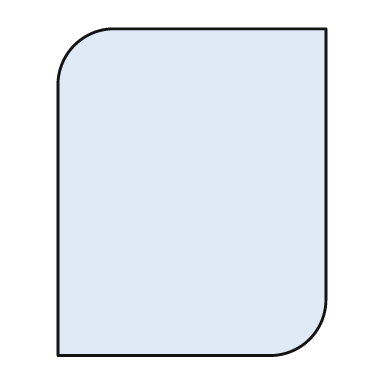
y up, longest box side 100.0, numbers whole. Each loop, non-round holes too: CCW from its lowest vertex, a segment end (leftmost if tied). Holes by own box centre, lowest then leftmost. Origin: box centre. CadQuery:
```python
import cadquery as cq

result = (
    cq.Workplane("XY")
    .moveTo(-41.0, -50.0)
    .lineTo(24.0, -50.0)
    .threePointArc((36.0, -45.0), (41.0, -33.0))
    .lineTo(41.0, 50.0)
    .lineTo(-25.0, 50.0)
    .threePointArc((-36.0, 45.0), (-41.0, 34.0))
    .close()
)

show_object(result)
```